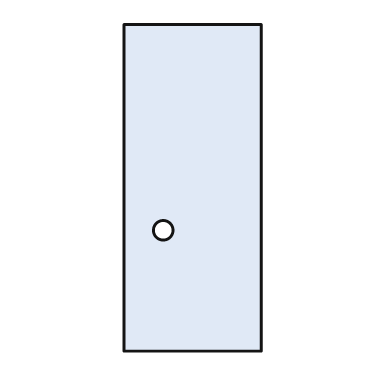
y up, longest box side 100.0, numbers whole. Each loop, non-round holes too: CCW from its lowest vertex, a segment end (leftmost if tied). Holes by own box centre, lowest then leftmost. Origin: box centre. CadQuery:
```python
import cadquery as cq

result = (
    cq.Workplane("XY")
    .moveTo(-21.0, -50.0)
    .lineTo(21.0, -50.0)
    .lineTo(21.0, 50.0)
    .lineTo(-21.0, 50.0)
    .close()
    .moveTo(-9.0, -13.0)
    .circle(3.0)
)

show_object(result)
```